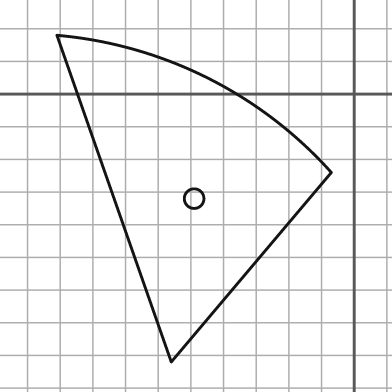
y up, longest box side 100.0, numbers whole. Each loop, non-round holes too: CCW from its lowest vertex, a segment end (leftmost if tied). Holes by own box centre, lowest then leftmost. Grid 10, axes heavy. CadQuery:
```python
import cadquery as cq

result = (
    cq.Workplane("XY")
    .moveTo(-56.0, -82.0)
    .lineTo(-7.0, -24.0)
    .threePointArc((-45.0, 5.0), (-91.0, 18.0))
    .close()
    .moveTo(-49.0, -32.0)
    .circle(3.0)
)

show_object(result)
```